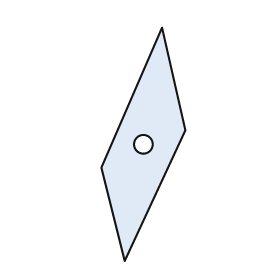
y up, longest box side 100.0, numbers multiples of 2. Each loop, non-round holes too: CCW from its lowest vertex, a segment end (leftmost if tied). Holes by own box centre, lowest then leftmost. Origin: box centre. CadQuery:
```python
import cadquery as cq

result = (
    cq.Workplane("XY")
    .moveTo(-8.0, -50.0)
    .lineTo(18.0, 6.0)
    .lineTo(8.0, 50.0)
    .lineTo(-18.0, -10.0)
    .close()
    .moveTo(0.0, 0.0)
    .circle(4.0)
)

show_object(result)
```